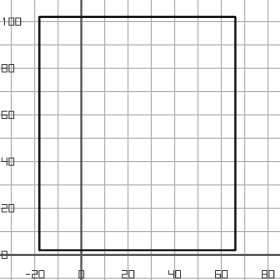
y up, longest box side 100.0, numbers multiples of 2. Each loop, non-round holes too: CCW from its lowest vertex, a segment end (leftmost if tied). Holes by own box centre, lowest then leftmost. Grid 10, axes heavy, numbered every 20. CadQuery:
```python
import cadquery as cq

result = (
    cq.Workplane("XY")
    .moveTo(-18.0, 2.0)
    .lineTo(66.0, 2.0)
    .lineTo(66.0, 102.0)
    .lineTo(-18.0, 102.0)
    .close()
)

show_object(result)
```